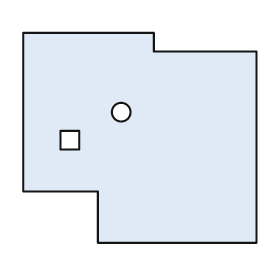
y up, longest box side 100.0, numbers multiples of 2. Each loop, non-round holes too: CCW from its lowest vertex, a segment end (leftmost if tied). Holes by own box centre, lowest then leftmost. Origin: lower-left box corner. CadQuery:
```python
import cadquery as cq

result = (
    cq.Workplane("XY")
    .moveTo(32.0, 0.0)
    .lineTo(100.0, 0.0)
    .lineTo(100.0, 82.0)
    .lineTo(56.0, 82.0)
    .lineTo(56.0, 90.0)
    .lineTo(0.0, 90.0)
    .lineTo(0.0, 22.0)
    .lineTo(32.0, 22.0)
    .close()
    .moveTo(16.0, 40.0)
    .lineTo(24.0, 40.0)
    .lineTo(24.0, 48.0)
    .lineTo(16.0, 48.0)
    .close()
    .moveTo(42.0, 56.0)
    .circle(4.0)
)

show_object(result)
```